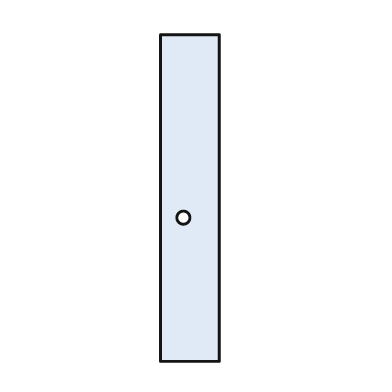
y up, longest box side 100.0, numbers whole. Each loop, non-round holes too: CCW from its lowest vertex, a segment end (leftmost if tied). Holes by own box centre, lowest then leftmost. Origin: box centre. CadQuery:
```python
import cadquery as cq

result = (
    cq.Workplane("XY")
    .moveTo(-9.0, -50.0)
    .lineTo(9.0, -50.0)
    .lineTo(9.0, 50.0)
    .lineTo(-9.0, 50.0)
    .close()
    .moveTo(-2.0, -6.0)
    .circle(2.0)
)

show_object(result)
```